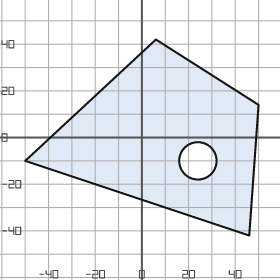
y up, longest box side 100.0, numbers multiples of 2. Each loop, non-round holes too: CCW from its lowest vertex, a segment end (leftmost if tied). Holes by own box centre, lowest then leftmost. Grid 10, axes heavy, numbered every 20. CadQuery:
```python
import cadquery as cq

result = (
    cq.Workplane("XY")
    .moveTo(46.0, -42.0)
    .lineTo(50.0, 14.0)
    .lineTo(6.0, 42.0)
    .lineTo(-50.0, -10.0)
    .close()
    .moveTo(24.0, -10.0)
    .circle(8.0)
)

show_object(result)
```